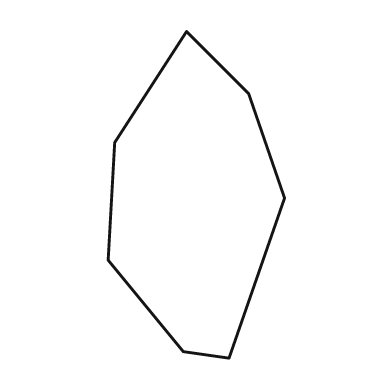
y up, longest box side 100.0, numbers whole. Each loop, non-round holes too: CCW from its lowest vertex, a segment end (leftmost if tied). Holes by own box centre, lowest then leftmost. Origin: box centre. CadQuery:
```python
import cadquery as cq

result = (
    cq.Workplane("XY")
    .moveTo(10.0, -50.0)
    .lineTo(27.0, -1.0)
    .lineTo(16.0, 31.0)
    .lineTo(-3.0, 50.0)
    .lineTo(-25.0, 16.0)
    .lineTo(-27.0, -20.0)
    .lineTo(-4.0, -48.0)
    .close()
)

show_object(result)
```